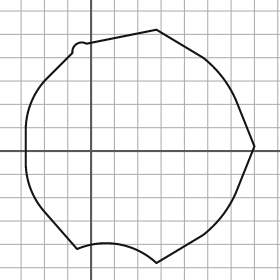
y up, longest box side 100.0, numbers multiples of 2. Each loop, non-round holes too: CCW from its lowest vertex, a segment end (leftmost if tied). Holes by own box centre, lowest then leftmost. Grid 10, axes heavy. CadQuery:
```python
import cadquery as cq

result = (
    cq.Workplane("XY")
    .moveTo(28.0, -48.0)
    .lineTo(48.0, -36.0)
    .threePointArc((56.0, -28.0), (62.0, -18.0))
    .lineTo(70.0, 2.0)
    .lineTo(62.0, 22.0)
    .threePointArc((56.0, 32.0), (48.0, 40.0))
    .lineTo(28.0, 52.0)
    .lineTo(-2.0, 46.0)
    .threePointArc((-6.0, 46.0), (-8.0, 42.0))
    .lineTo(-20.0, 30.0)
    .threePointArc((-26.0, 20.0), (-28.0, 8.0))
    .lineTo(-28.0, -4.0)
    .threePointArc((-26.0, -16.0), (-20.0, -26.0))
    .lineTo(-6.0, -42.0)
    .threePointArc((12.0, -40.0), (28.0, -48.0))
    .close()
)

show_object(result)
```